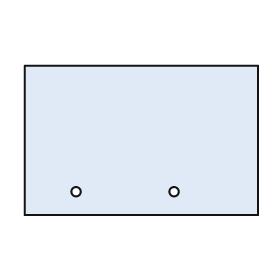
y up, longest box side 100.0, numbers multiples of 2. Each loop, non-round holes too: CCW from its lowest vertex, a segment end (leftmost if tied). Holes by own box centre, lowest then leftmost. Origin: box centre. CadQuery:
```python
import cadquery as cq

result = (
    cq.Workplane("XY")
    .moveTo(-50.0, -32.0)
    .lineTo(50.0, -32.0)
    .lineTo(50.0, 32.0)
    .lineTo(-50.0, 32.0)
    .close()
    .moveTo(-28.0, -22.0)
    .circle(2.0)
    .moveTo(14.0, -22.0)
    .circle(2.0)
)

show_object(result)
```